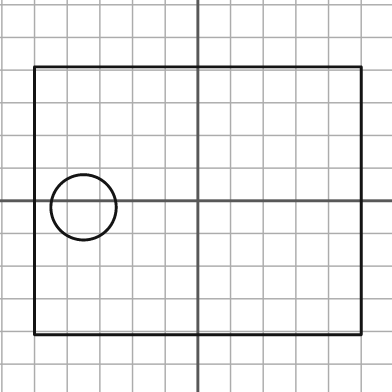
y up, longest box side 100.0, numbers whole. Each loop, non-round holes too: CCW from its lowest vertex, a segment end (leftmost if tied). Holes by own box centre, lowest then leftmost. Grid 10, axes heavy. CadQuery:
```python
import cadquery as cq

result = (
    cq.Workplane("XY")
    .moveTo(-50.0, -41.0)
    .lineTo(50.0, -41.0)
    .lineTo(50.0, 41.0)
    .lineTo(-50.0, 41.0)
    .close()
    .moveTo(-35.0, -2.0)
    .circle(10.0)
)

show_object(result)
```